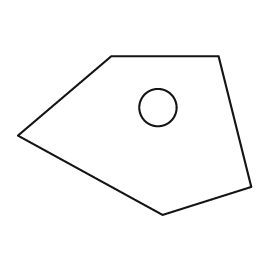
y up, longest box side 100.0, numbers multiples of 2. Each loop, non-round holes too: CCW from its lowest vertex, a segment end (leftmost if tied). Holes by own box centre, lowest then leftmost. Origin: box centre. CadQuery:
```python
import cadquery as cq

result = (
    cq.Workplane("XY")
    .moveTo(12.0, -34.0)
    .lineTo(50.0, -22.0)
    .lineTo(36.0, 34.0)
    .lineTo(-10.0, 34.0)
    .lineTo(-50.0, 0.0)
    .close()
    .moveTo(10.0, 12.0)
    .circle(8.0)
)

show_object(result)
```